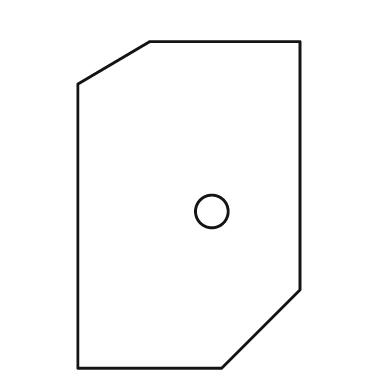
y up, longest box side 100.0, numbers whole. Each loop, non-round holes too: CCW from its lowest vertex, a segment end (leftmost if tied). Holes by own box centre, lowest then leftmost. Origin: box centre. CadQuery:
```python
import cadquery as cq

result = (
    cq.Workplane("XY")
    .moveTo(-34.0, -50.0)
    .lineTo(10.0, -50.0)
    .lineTo(34.0, -26.0)
    .lineTo(34.0, 50.0)
    .lineTo(-12.0, 50.0)
    .lineTo(-34.0, 37.0)
    .close()
    .moveTo(7.0, -2.0)
    .circle(5.0)
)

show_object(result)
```